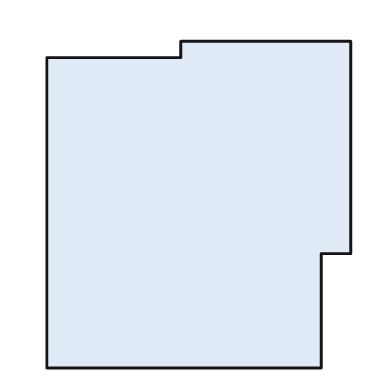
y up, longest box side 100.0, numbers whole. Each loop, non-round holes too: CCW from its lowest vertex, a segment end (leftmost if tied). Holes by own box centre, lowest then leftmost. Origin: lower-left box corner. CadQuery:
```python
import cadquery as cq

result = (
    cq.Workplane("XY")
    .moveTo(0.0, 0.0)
    .lineTo(84.0, 0.0)
    .lineTo(84.0, 35.0)
    .lineTo(93.0, 35.0)
    .lineTo(93.0, 100.0)
    .lineTo(41.0, 100.0)
    .lineTo(41.0, 95.0)
    .lineTo(0.0, 95.0)
    .close()
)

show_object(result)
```